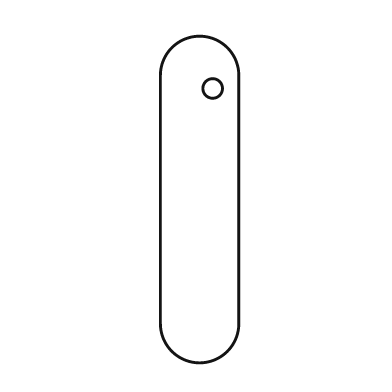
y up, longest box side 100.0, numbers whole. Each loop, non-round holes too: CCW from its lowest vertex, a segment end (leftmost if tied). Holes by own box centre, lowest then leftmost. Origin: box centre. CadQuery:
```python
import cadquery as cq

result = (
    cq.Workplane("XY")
    .moveTo(-12.0, -38.0)
    .threePointArc((0.0, -50.0), (12.0, -38.0))
    .lineTo(12.0, 38.0)
    .threePointArc((0.0, 50.0), (-12.0, 38.0))
    .close()
    .moveTo(4.0, 34.0)
    .circle(3.0)
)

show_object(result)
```